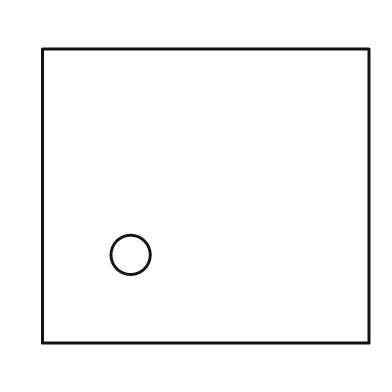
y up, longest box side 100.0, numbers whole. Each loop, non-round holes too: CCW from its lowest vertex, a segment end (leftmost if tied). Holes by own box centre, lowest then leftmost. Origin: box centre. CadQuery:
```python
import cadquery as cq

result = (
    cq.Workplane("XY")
    .moveTo(-50.0, -45.0)
    .lineTo(50.0, -45.0)
    .lineTo(50.0, 45.0)
    .lineTo(-50.0, 45.0)
    .close()
    .moveTo(-23.0, -18.0)
    .circle(6.0)
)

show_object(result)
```